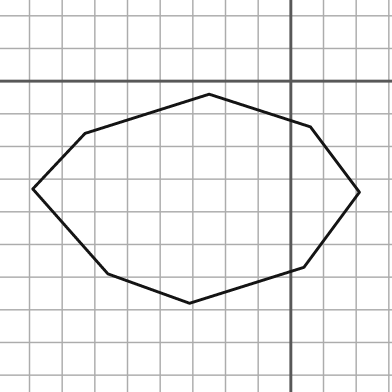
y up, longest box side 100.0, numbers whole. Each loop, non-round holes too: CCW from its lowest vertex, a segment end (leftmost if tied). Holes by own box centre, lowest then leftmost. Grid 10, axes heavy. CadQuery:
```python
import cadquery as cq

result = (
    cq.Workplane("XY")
    .moveTo(-31.0, -68.0)
    .lineTo(4.0, -57.0)
    .lineTo(21.0, -34.0)
    .lineTo(6.0, -14.0)
    .lineTo(-25.0, -4.0)
    .lineTo(-63.0, -16.0)
    .lineTo(-79.0, -33.0)
    .lineTo(-56.0, -59.0)
    .close()
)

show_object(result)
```